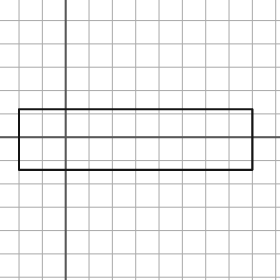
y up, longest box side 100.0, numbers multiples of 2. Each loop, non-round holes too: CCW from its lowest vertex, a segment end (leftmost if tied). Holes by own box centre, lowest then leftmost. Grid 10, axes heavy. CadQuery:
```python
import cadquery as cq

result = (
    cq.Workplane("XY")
    .moveTo(-20.0, -14.0)
    .lineTo(80.0, -14.0)
    .lineTo(80.0, 12.0)
    .lineTo(-20.0, 12.0)
    .close()
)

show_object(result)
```